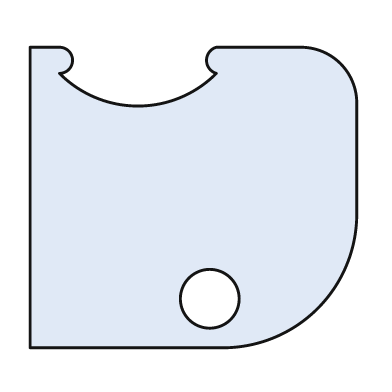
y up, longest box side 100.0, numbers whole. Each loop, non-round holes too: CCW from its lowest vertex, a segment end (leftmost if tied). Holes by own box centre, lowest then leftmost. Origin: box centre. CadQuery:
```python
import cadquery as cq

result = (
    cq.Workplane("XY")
    .moveTo(-50.0, -46.0)
    .lineTo(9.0, -46.0)
    .threePointArc((38.0, -34.0), (50.0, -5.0))
    .lineTo(50.0, 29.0)
    .threePointArc((45.0, 41.0), (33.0, 46.0))
    .lineTo(7.0, 46.0)
    .threePointArc((4.0, 42.0), (7.0, 38.0))
    .threePointArc((-17.0, 28.0), (-41.0, 38.0))
    .threePointArc((-37.0, 42.0), (-41.0, 46.0))
    .lineTo(-50.0, 46.0)
    .close()
    .moveTo(5.0, -31.0)
    .circle(9.0)
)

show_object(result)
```